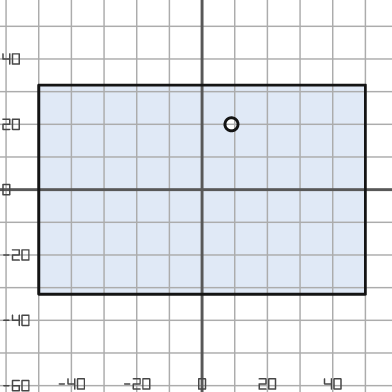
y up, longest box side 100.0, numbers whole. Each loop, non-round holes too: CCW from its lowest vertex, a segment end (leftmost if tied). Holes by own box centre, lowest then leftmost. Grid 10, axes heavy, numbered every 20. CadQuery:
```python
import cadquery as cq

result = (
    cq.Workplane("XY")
    .moveTo(-50.0, -32.0)
    .lineTo(50.0, -32.0)
    .lineTo(50.0, 32.0)
    .lineTo(-50.0, 32.0)
    .close()
    .moveTo(9.0, 20.0)
    .circle(2.0)
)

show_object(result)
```